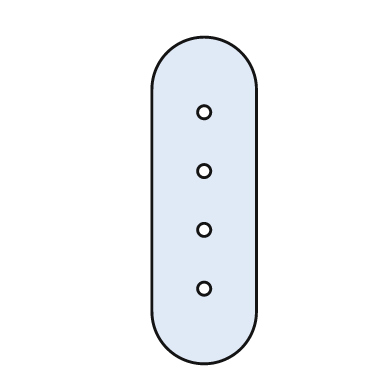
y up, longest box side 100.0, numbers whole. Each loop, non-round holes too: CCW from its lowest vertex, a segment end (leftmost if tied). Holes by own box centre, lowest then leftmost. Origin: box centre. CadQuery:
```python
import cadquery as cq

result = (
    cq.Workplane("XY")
    .moveTo(-16.0, -34.0)
    .threePointArc((0.0, -50.0), (16.0, -34.0))
    .lineTo(16.0, 34.0)
    .threePointArc((0.0, 50.0), (-16.0, 34.0))
    .close()
    .moveTo(0.0, -27.0)
    .circle(2.0)
    .moveTo(0.0, -9.0)
    .circle(2.0)
    .moveTo(0.0, 9.0)
    .circle(2.0)
    .moveTo(0.0, 27.0)
    .circle(2.0)
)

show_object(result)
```